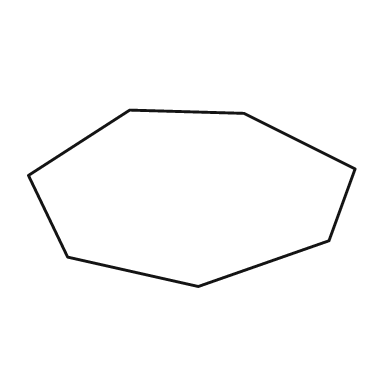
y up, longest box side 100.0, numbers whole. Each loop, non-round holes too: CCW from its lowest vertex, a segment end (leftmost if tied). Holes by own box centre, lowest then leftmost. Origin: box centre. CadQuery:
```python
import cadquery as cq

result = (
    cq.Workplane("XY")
    .moveTo(2.0, -27.0)
    .lineTo(42.0, -13.0)
    .lineTo(50.0, 9.0)
    .lineTo(16.0, 26.0)
    .lineTo(-19.0, 27.0)
    .lineTo(-50.0, 7.0)
    .lineTo(-38.0, -18.0)
    .close()
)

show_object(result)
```